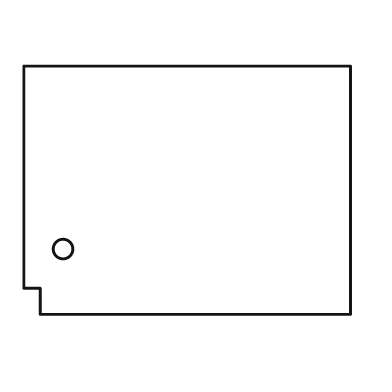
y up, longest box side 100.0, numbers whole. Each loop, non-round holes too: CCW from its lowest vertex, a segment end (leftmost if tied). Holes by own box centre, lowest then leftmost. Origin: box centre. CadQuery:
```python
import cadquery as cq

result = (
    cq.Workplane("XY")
    .moveTo(-45.0, -38.0)
    .lineTo(50.0, -38.0)
    .lineTo(50.0, 38.0)
    .lineTo(-50.0, 38.0)
    .lineTo(-50.0, -30.0)
    .lineTo(-45.0, -30.0)
    .close()
    .moveTo(-38.0, -18.0)
    .circle(3.0)
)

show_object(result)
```